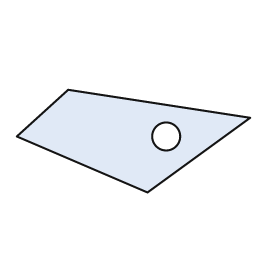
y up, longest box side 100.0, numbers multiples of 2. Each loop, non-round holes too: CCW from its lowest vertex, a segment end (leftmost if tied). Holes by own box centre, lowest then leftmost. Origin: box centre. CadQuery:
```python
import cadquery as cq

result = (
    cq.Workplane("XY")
    .moveTo(6.0, -22.0)
    .lineTo(50.0, 10.0)
    .lineTo(-28.0, 22.0)
    .lineTo(-50.0, 2.0)
    .close()
    .moveTo(14.0, 2.0)
    .circle(6.0)
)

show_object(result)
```